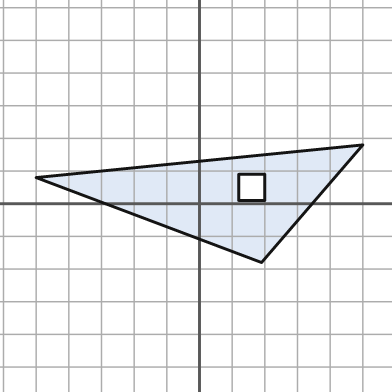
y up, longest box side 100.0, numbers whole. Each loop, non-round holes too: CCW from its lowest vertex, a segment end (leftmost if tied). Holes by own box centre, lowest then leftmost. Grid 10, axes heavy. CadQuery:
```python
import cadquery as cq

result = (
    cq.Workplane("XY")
    .moveTo(19.0, -18.0)
    .lineTo(50.0, 18.0)
    .lineTo(-50.0, 8.0)
    .close()
    .moveTo(12.0, 1.0)
    .lineTo(20.0, 1.0)
    .lineTo(20.0, 9.0)
    .lineTo(12.0, 9.0)
    .close()
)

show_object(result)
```